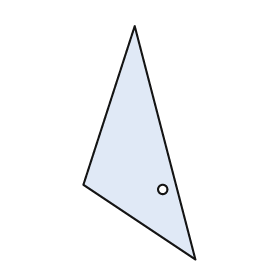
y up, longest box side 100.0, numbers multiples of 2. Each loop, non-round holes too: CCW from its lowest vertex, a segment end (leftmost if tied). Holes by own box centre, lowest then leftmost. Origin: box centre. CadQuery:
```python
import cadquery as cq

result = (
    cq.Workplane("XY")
    .moveTo(24.0, -50.0)
    .lineTo(-2.0, 50.0)
    .lineTo(-24.0, -18.0)
    .close()
    .moveTo(10.0, -20.0)
    .circle(2.0)
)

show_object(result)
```